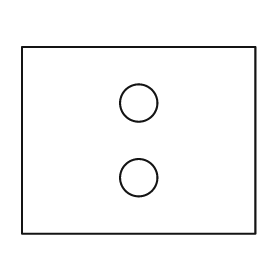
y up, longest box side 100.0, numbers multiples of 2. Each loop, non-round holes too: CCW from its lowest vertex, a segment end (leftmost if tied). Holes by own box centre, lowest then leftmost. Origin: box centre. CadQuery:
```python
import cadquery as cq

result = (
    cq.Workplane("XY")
    .moveTo(-50.0, -40.0)
    .lineTo(50.0, -40.0)
    .lineTo(50.0, 40.0)
    .lineTo(-50.0, 40.0)
    .close()
    .moveTo(0.0, -16.0)
    .circle(8.0)
    .moveTo(0.0, 16.0)
    .circle(8.0)
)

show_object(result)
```